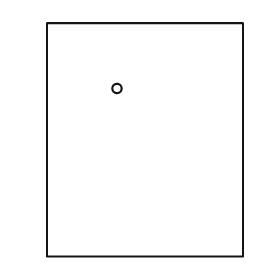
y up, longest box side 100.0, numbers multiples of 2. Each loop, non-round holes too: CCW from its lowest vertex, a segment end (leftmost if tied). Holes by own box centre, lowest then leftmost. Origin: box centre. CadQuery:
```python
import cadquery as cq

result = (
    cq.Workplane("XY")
    .moveTo(-42.0, -50.0)
    .lineTo(42.0, -50.0)
    .lineTo(42.0, 50.0)
    .lineTo(-42.0, 50.0)
    .close()
    .moveTo(-12.0, 22.0)
    .circle(2.0)
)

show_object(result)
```